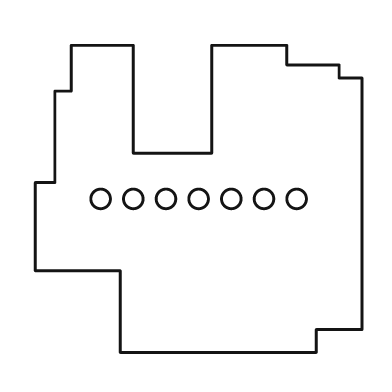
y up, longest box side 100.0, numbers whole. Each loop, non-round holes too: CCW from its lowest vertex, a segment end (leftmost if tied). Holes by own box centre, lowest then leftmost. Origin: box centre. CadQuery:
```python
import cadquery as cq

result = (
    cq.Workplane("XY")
    .moveTo(-24.0, -47.0)
    .lineTo(36.0, -47.0)
    .lineTo(36.0, -40.0)
    .lineTo(50.0, -40.0)
    .lineTo(50.0, 37.0)
    .lineTo(43.0, 37.0)
    .lineTo(43.0, 41.0)
    .lineTo(27.0, 41.0)
    .lineTo(27.0, 47.0)
    .lineTo(4.0, 47.0)
    .lineTo(4.0, 14.0)
    .lineTo(-20.0, 14.0)
    .lineTo(-20.0, 47.0)
    .lineTo(-39.0, 47.0)
    .lineTo(-39.0, 33.0)
    .lineTo(-44.0, 33.0)
    .lineTo(-44.0, 5.0)
    .lineTo(-50.0, 5.0)
    .lineTo(-50.0, -22.0)
    .lineTo(-24.0, -22.0)
    .close()
    .moveTo(-30.0, 0.0)
    .circle(3.0)
    .moveTo(-20.0, 0.0)
    .circle(3.0)
    .moveTo(-10.0, 0.0)
    .circle(3.0)
    .moveTo(0.0, 0.0)
    .circle(3.0)
    .moveTo(10.0, 0.0)
    .circle(3.0)
    .moveTo(20.0, 0.0)
    .circle(3.0)
    .moveTo(30.0, 0.0)
    .circle(3.0)
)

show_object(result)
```